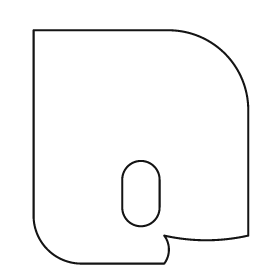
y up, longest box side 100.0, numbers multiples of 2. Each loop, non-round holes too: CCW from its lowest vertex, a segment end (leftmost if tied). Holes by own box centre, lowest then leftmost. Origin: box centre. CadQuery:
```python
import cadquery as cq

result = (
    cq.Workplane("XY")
    .moveTo(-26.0, -50.0)
    .lineTo(10.0, -50.0)
    .threePointArc((12.0, -44.0), (10.0, -38.0))
    .threePointArc((28.0, -40.0), (46.0, -38.0))
    .lineTo(46.0, 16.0)
    .threePointArc((36.0, 40.0), (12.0, 50.0))
    .lineTo(-46.0, 50.0)
    .lineTo(-46.0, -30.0)
    .threePointArc((-40.0, -44.0), (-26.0, -50.0))
    .close()
    .moveTo(-8.0, -26.0)
    .threePointArc((0.0, -34.0), (8.0, -26.0))
    .lineTo(8.0, -14.0)
    .threePointArc((0.0, -6.0), (-8.0, -14.0))
    .close()
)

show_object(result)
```